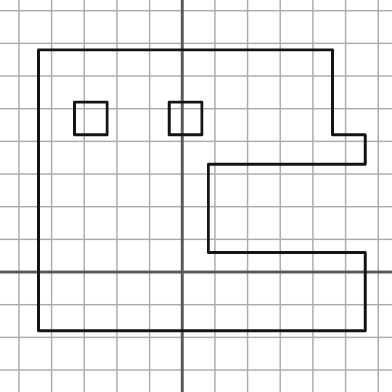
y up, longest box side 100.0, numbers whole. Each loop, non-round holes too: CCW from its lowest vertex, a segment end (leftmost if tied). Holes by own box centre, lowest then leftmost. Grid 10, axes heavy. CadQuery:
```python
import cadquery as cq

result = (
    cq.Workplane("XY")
    .moveTo(-44.0, -18.0)
    .lineTo(56.0, -18.0)
    .lineTo(56.0, 6.0)
    .lineTo(8.0, 6.0)
    .lineTo(8.0, 33.0)
    .lineTo(56.0, 33.0)
    .lineTo(56.0, 42.0)
    .lineTo(46.0, 42.0)
    .lineTo(46.0, 68.0)
    .lineTo(-44.0, 68.0)
    .close()
    .moveTo(-33.0, 42.0)
    .lineTo(-23.0, 42.0)
    .lineTo(-23.0, 52.0)
    .lineTo(-33.0, 52.0)
    .close()
    .moveTo(-4.0, 42.0)
    .lineTo(6.0, 42.0)
    .lineTo(6.0, 52.0)
    .lineTo(-4.0, 52.0)
    .close()
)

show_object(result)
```